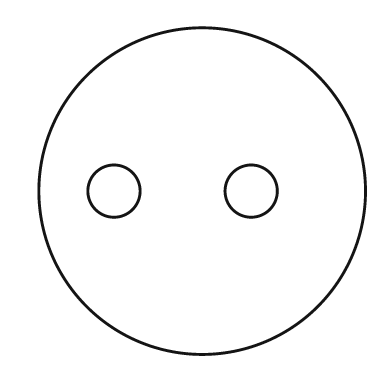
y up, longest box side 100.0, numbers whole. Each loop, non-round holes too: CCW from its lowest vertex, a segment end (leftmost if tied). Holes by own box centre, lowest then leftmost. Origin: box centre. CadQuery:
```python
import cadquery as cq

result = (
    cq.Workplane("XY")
    .moveTo(0.0, 0.0)
    .circle(50.0)
    .moveTo(-27.0, 0.0)
    .circle(8.0)
    .moveTo(15.0, 0.0)
    .circle(8.0)
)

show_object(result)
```